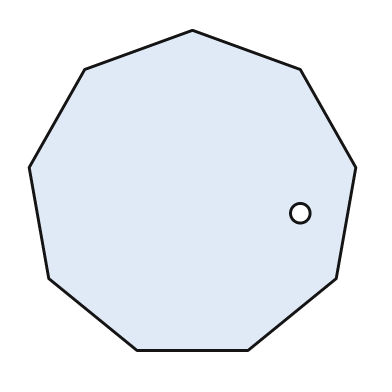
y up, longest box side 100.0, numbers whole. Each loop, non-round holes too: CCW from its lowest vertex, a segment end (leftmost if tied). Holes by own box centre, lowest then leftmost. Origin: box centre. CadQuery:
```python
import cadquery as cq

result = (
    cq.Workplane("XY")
    .moveTo(-17.0, -49.0)
    .lineTo(17.0, -49.0)
    .lineTo(44.0, -27.0)
    .lineTo(50.0, 7.0)
    .lineTo(33.0, 37.0)
    .lineTo(0.0, 49.0)
    .lineTo(-33.0, 37.0)
    .lineTo(-50.0, 7.0)
    .lineTo(-44.0, -27.0)
    .close()
    .moveTo(33.0, -7.0)
    .circle(3.0)
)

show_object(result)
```